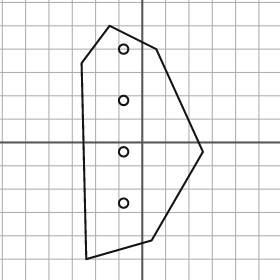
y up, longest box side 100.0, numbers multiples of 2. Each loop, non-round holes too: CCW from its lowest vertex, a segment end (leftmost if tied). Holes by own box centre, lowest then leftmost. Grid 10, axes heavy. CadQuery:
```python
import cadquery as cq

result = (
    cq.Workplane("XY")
    .moveTo(-24.0, -50.0)
    .lineTo(4.0, -42.0)
    .lineTo(26.0, -4.0)
    .lineTo(6.0, 40.0)
    .lineTo(-14.0, 50.0)
    .lineTo(-26.0, 34.0)
    .close()
    .moveTo(-8.0, -26.0)
    .circle(2.0)
    .moveTo(-8.0, -4.0)
    .circle(2.0)
    .moveTo(-8.0, 18.0)
    .circle(2.0)
    .moveTo(-8.0, 40.0)
    .circle(2.0)
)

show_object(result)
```